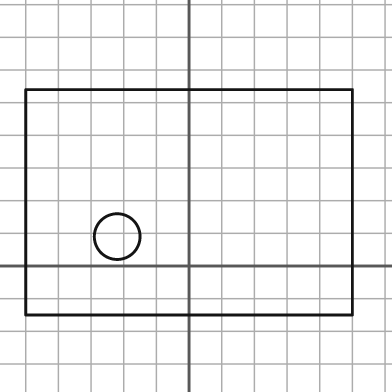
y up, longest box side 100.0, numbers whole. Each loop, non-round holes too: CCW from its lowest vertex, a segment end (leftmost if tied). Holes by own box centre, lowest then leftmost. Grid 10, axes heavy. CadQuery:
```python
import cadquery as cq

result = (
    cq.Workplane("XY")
    .moveTo(-50.0, -15.0)
    .lineTo(50.0, -15.0)
    .lineTo(50.0, 54.0)
    .lineTo(-50.0, 54.0)
    .close()
    .moveTo(-22.0, 9.0)
    .circle(7.0)
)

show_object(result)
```